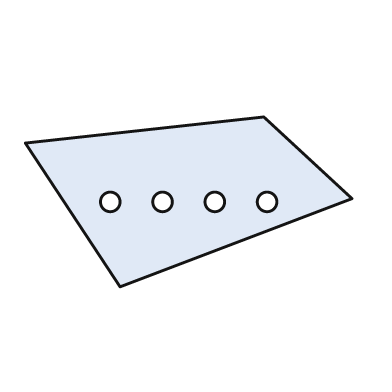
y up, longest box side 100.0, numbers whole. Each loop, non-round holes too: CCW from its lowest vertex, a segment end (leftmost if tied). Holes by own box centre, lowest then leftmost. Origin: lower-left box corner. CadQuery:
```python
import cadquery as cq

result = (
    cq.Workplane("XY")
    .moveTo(29.0, 0.0)
    .lineTo(100.0, 27.0)
    .lineTo(73.0, 52.0)
    .lineTo(0.0, 44.0)
    .close()
    .moveTo(26.0, 26.0)
    .circle(3.0)
    .moveTo(42.0, 26.0)
    .circle(3.0)
    .moveTo(58.0, 26.0)
    .circle(3.0)
    .moveTo(74.0, 26.0)
    .circle(3.0)
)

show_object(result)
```